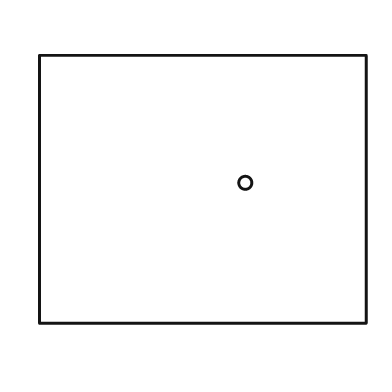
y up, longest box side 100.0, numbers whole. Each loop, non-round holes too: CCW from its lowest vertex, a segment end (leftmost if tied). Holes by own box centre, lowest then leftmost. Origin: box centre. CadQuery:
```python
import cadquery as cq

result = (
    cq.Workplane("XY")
    .moveTo(-50.0, -41.0)
    .lineTo(50.0, -41.0)
    .lineTo(50.0, 41.0)
    .lineTo(-50.0, 41.0)
    .close()
    .moveTo(13.0, 2.0)
    .circle(2.0)
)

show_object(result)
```